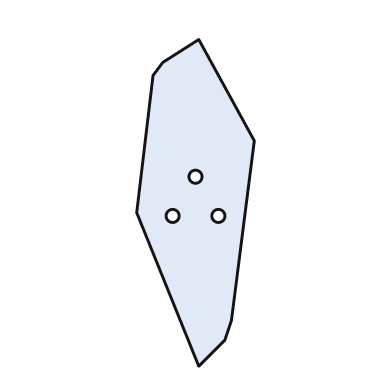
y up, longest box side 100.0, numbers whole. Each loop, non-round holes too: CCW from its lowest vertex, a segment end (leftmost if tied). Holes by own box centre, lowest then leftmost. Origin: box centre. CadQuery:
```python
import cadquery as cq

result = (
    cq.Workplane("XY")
    .moveTo(1.0, -50.0)
    .lineTo(9.0, -42.0)
    .lineTo(11.0, -36.0)
    .lineTo(18.0, 19.0)
    .lineTo(1.0, 50.0)
    .lineTo(-10.0, 43.0)
    .lineTo(-13.0, 39.0)
    .lineTo(-18.0, -3.0)
    .close()
    .moveTo(-7.0, -4.0)
    .circle(2.0)
    .moveTo(7.0, -4.0)
    .circle(2.0)
    .moveTo(0.0, 8.0)
    .circle(2.0)
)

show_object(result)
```